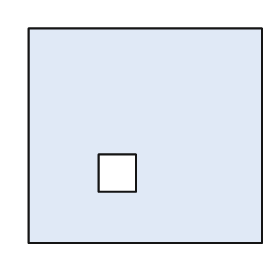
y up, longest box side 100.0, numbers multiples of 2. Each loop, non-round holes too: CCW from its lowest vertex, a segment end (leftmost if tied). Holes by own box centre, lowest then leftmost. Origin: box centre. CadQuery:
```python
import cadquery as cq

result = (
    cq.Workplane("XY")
    .moveTo(-50.0, -46.0)
    .lineTo(50.0, -46.0)
    .lineTo(50.0, 46.0)
    .lineTo(-50.0, 46.0)
    .close()
    .moveTo(-20.0, -24.0)
    .lineTo(-4.0, -24.0)
    .lineTo(-4.0, -8.0)
    .lineTo(-20.0, -8.0)
    .close()
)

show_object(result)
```